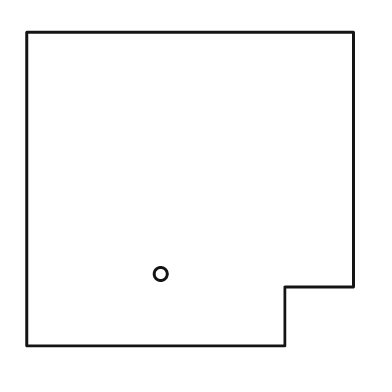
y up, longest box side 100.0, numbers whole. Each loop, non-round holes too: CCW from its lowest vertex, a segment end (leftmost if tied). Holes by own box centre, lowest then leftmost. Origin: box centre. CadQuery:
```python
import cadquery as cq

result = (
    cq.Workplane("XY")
    .moveTo(-50.0, -48.0)
    .lineTo(29.0, -48.0)
    .lineTo(29.0, -30.0)
    .lineTo(50.0, -30.0)
    .lineTo(50.0, 48.0)
    .lineTo(-50.0, 48.0)
    .close()
    .moveTo(-9.0, -26.0)
    .circle(2.0)
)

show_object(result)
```